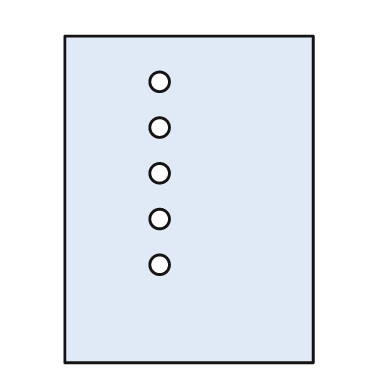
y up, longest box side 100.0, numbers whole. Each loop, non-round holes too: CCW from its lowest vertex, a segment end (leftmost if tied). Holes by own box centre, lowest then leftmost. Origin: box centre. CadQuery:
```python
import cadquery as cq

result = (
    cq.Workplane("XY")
    .moveTo(-38.0, -50.0)
    .lineTo(38.0, -50.0)
    .lineTo(38.0, 50.0)
    .lineTo(-38.0, 50.0)
    .close()
    .moveTo(-9.0, -20.0)
    .circle(3.0)
    .moveTo(-9.0, -6.0)
    .circle(3.0)
    .moveTo(-9.0, 8.0)
    .circle(3.0)
    .moveTo(-9.0, 22.0)
    .circle(3.0)
    .moveTo(-9.0, 36.0)
    .circle(3.0)
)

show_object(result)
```